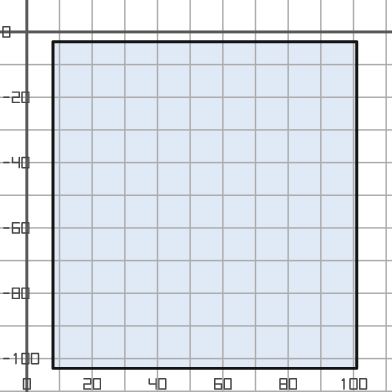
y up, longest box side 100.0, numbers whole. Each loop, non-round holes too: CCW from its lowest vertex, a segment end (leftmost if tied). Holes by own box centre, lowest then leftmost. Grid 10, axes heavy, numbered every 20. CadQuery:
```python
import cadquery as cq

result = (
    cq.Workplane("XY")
    .moveTo(8.0, -103.0)
    .lineTo(101.0, -103.0)
    .lineTo(101.0, -3.0)
    .lineTo(8.0, -3.0)
    .close()
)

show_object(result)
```